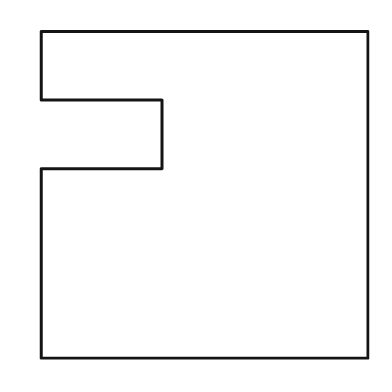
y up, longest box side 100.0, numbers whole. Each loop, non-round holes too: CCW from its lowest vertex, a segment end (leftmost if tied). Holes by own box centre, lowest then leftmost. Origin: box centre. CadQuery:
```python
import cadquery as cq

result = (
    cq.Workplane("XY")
    .moveTo(-50.0, -50.0)
    .lineTo(50.0, -50.0)
    .lineTo(50.0, 50.0)
    .lineTo(-50.0, 50.0)
    .lineTo(-50.0, 29.0)
    .lineTo(-13.0, 29.0)
    .lineTo(-13.0, 8.0)
    .lineTo(-50.0, 8.0)
    .close()
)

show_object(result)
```